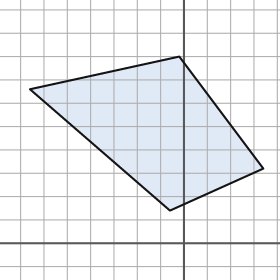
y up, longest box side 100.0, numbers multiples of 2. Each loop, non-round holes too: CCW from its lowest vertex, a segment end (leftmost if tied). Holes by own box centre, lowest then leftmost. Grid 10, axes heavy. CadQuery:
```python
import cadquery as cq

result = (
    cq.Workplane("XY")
    .moveTo(-6.0, 14.0)
    .lineTo(34.0, 32.0)
    .lineTo(-2.0, 80.0)
    .lineTo(-66.0, 66.0)
    .close()
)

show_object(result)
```